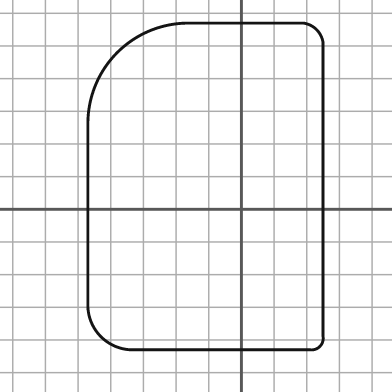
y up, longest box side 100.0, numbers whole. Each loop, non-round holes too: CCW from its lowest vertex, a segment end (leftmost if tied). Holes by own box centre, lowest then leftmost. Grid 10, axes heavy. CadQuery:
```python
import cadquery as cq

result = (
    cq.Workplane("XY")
    .moveTo(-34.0, -43.0)
    .lineTo(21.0, -43.0)
    .threePointArc((24.0, -42.0), (25.0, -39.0))
    .lineTo(25.0, 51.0)
    .threePointArc((23.0, 55.0), (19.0, 57.0))
    .lineTo(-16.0, 57.0)
    .threePointArc((-38.0, 48.0), (-47.0, 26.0))
    .lineTo(-47.0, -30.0)
    .threePointArc((-43.0, -39.0), (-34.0, -43.0))
    .close()
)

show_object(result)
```